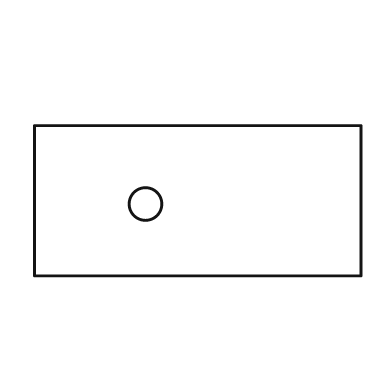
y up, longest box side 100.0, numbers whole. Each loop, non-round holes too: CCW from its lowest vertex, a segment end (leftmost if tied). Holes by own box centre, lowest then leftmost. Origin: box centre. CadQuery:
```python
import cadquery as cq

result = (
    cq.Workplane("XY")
    .moveTo(-50.0, -23.0)
    .lineTo(50.0, -23.0)
    .lineTo(50.0, 23.0)
    .lineTo(-50.0, 23.0)
    .close()
    .moveTo(-16.0, -1.0)
    .circle(5.0)
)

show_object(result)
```